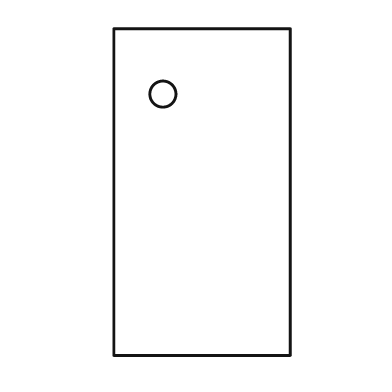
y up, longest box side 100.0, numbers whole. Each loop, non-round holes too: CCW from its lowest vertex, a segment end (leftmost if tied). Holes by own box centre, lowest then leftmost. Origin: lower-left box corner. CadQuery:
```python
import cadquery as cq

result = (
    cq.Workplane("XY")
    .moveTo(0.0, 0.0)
    .lineTo(54.0, 0.0)
    .lineTo(54.0, 100.0)
    .lineTo(0.0, 100.0)
    .close()
    .moveTo(15.0, 80.0)
    .circle(4.0)
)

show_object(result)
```